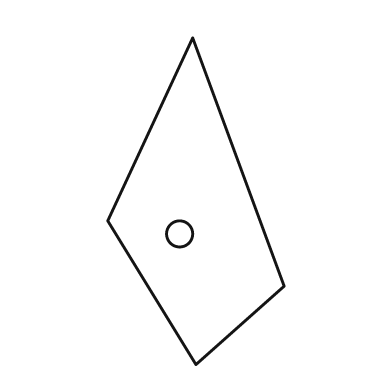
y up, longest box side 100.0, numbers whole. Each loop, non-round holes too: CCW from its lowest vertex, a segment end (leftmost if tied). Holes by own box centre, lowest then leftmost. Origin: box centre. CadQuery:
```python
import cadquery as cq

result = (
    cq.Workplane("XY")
    .moveTo(0.0, -50.0)
    .lineTo(27.0, -26.0)
    .lineTo(-1.0, 50.0)
    .lineTo(-27.0, -6.0)
    .close()
    .moveTo(-5.0, -10.0)
    .circle(4.0)
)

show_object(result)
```